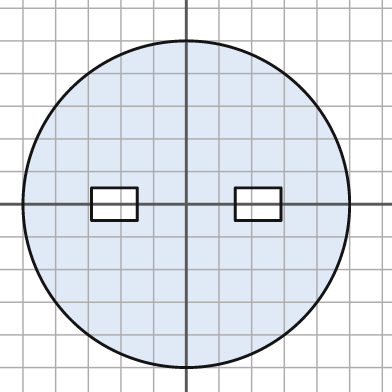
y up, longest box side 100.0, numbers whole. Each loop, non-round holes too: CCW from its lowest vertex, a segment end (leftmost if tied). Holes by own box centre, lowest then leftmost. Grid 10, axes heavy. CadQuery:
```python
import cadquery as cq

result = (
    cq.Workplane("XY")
    .moveTo(0.0, 0.0)
    .circle(50.0)
    .moveTo(-29.0, -5.0)
    .lineTo(-15.0, -5.0)
    .lineTo(-15.0, 5.0)
    .lineTo(-29.0, 5.0)
    .close()
    .moveTo(15.0, -5.0)
    .lineTo(29.0, -5.0)
    .lineTo(29.0, 5.0)
    .lineTo(15.0, 5.0)
    .close()
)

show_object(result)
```